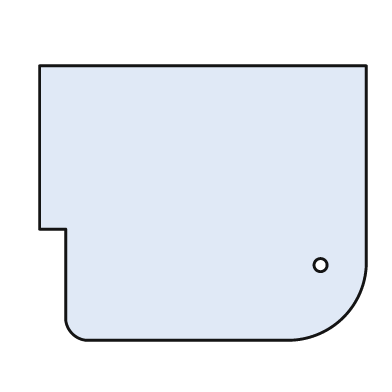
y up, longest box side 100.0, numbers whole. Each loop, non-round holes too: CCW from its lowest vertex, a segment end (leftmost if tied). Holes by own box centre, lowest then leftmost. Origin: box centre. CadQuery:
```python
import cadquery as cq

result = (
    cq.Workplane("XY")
    .moveTo(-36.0, -42.0)
    .lineTo(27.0, -42.0)
    .threePointArc((43.0, -35.0), (50.0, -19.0))
    .lineTo(50.0, 42.0)
    .lineTo(-50.0, 42.0)
    .lineTo(-50.0, -8.0)
    .lineTo(-42.0, -8.0)
    .lineTo(-42.0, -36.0)
    .threePointArc((-40.0, -40.0), (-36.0, -42.0))
    .close()
    .moveTo(36.0, -19.0)
    .circle(2.0)
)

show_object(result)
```